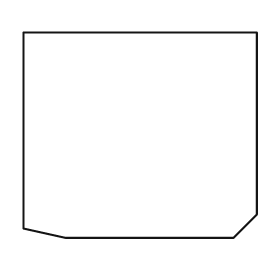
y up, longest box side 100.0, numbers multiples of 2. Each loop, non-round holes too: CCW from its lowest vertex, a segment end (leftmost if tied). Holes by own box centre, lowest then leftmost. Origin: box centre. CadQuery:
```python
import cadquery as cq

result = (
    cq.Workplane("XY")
    .moveTo(-32.0, -44.0)
    .lineTo(40.0, -44.0)
    .lineTo(50.0, -34.0)
    .lineTo(50.0, 44.0)
    .lineTo(-50.0, 44.0)
    .lineTo(-50.0, -40.0)
    .close()
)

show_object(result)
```